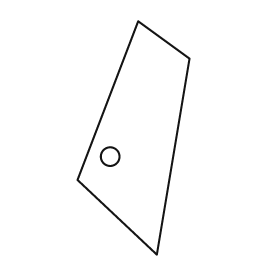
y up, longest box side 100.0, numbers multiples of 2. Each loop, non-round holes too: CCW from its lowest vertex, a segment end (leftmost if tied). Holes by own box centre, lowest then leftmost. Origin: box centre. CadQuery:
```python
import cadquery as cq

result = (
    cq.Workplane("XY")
    .moveTo(10.0, -50.0)
    .lineTo(24.0, 34.0)
    .lineTo(2.0, 50.0)
    .lineTo(-24.0, -18.0)
    .close()
    .moveTo(-10.0, -8.0)
    .circle(4.0)
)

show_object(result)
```